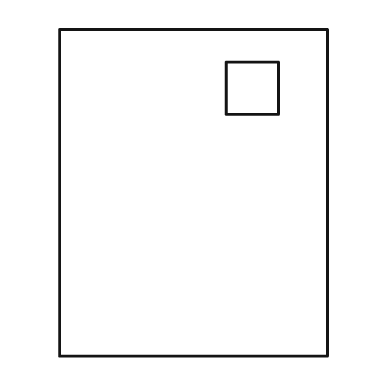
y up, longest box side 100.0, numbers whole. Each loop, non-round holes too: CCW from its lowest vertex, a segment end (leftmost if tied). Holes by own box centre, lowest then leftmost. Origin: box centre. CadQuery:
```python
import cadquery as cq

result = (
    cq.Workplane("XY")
    .moveTo(-41.0, -50.0)
    .lineTo(41.0, -50.0)
    .lineTo(41.0, 50.0)
    .lineTo(-41.0, 50.0)
    .close()
    .moveTo(10.0, 24.0)
    .lineTo(26.0, 24.0)
    .lineTo(26.0, 40.0)
    .lineTo(10.0, 40.0)
    .close()
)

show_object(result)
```